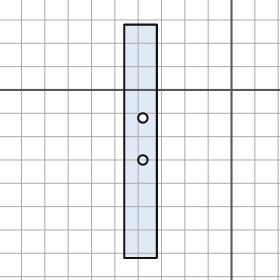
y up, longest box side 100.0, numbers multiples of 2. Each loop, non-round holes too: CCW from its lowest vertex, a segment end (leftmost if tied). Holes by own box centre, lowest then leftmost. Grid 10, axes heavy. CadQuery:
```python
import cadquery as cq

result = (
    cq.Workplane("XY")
    .moveTo(-46.0, -72.0)
    .lineTo(-32.0, -72.0)
    .lineTo(-32.0, 28.0)
    .lineTo(-46.0, 28.0)
    .close()
    .moveTo(-38.0, -30.0)
    .circle(2.0)
    .moveTo(-38.0, -12.0)
    .circle(2.0)
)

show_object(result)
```